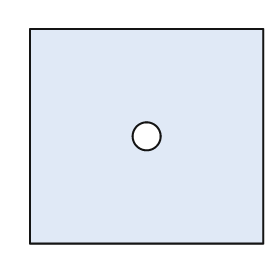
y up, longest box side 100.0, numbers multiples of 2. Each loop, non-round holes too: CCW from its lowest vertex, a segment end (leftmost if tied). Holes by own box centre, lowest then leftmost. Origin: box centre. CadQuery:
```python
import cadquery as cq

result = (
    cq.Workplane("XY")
    .moveTo(-50.0, -46.0)
    .lineTo(50.0, -46.0)
    .lineTo(50.0, 46.0)
    .lineTo(-50.0, 46.0)
    .close()
    .moveTo(0.0, 0.0)
    .circle(6.0)
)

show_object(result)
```